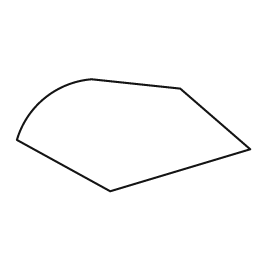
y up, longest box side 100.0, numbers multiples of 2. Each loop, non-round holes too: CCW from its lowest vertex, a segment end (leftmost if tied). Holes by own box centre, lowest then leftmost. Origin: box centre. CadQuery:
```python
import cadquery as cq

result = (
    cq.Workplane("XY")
    .moveTo(-10.0, -24.0)
    .lineTo(50.0, -6.0)
    .lineTo(20.0, 20.0)
    .lineTo(-18.0, 24.0)
    .threePointArc((-38.0, 16.0), (-50.0, -2.0))
    .close()
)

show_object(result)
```